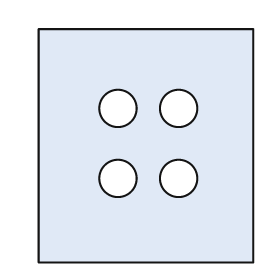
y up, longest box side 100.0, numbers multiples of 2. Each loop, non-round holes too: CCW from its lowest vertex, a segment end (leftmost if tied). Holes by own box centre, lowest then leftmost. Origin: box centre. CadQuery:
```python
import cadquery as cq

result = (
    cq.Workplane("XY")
    .moveTo(-46.0, -50.0)
    .lineTo(46.0, -50.0)
    .lineTo(46.0, 50.0)
    .lineTo(-46.0, 50.0)
    .close()
    .moveTo(-12.0, -14.0)
    .circle(8.0)
    .moveTo(14.0, -14.0)
    .circle(8.0)
    .moveTo(-12.0, 16.0)
    .circle(8.0)
    .moveTo(14.0, 16.0)
    .circle(8.0)
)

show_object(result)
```